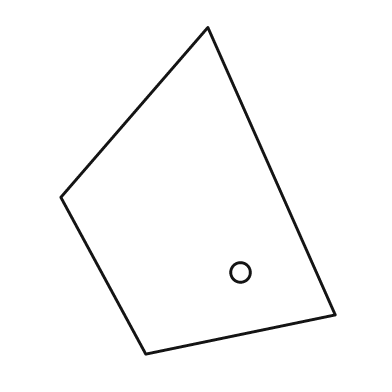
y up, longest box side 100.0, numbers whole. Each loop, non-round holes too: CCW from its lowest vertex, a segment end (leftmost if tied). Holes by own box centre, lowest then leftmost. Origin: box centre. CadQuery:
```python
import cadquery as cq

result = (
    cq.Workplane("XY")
    .moveTo(-16.0, -50.0)
    .lineTo(42.0, -38.0)
    .lineTo(3.0, 50.0)
    .lineTo(-42.0, -2.0)
    .close()
    .moveTo(13.0, -25.0)
    .circle(3.0)
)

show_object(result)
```